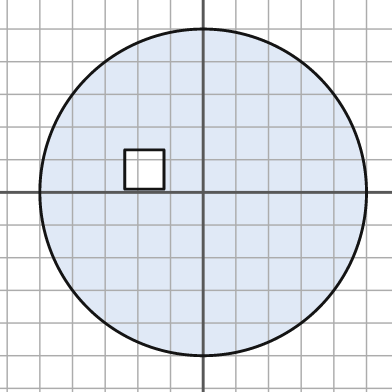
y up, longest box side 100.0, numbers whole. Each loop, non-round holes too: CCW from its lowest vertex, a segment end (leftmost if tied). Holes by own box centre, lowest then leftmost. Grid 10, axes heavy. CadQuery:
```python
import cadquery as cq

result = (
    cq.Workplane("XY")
    .moveTo(0.0, 0.0)
    .circle(50.0)
    .moveTo(-24.0, 1.0)
    .lineTo(-12.0, 1.0)
    .lineTo(-12.0, 13.0)
    .lineTo(-24.0, 13.0)
    .close()
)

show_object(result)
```